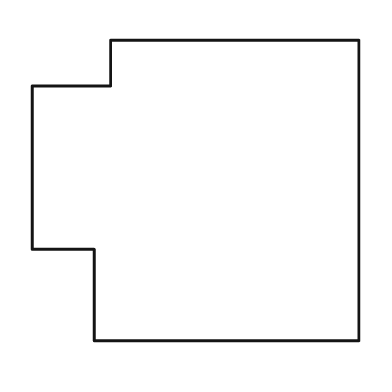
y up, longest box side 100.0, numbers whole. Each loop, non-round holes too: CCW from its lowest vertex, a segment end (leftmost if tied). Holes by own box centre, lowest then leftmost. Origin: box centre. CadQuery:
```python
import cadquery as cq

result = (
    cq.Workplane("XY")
    .moveTo(-31.0, -46.0)
    .lineTo(50.0, -46.0)
    .lineTo(50.0, 46.0)
    .lineTo(-26.0, 46.0)
    .lineTo(-26.0, 32.0)
    .lineTo(-50.0, 32.0)
    .lineTo(-50.0, -18.0)
    .lineTo(-31.0, -18.0)
    .close()
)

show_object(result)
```